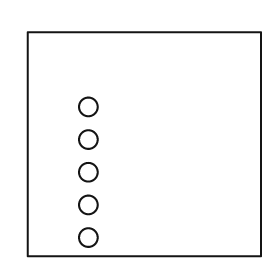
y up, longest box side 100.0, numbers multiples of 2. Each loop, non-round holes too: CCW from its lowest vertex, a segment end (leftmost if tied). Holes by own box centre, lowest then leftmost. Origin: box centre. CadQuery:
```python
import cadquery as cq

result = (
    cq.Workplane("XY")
    .moveTo(-50.0, -48.0)
    .lineTo(50.0, -48.0)
    .lineTo(50.0, 48.0)
    .lineTo(-50.0, 48.0)
    .close()
    .moveTo(-24.0, -40.0)
    .circle(4.0)
    .moveTo(-24.0, -26.0)
    .circle(4.0)
    .moveTo(-24.0, -12.0)
    .circle(4.0)
    .moveTo(-24.0, 2.0)
    .circle(4.0)
    .moveTo(-24.0, 16.0)
    .circle(4.0)
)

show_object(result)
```